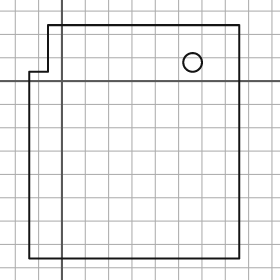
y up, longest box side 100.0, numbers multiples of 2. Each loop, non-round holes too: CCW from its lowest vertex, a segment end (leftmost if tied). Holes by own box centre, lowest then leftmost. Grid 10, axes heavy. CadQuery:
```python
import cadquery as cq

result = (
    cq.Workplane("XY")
    .moveTo(-14.0, -76.0)
    .lineTo(76.0, -76.0)
    .lineTo(76.0, 24.0)
    .lineTo(-6.0, 24.0)
    .lineTo(-6.0, 4.0)
    .lineTo(-14.0, 4.0)
    .close()
    .moveTo(56.0, 8.0)
    .circle(4.0)
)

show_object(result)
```